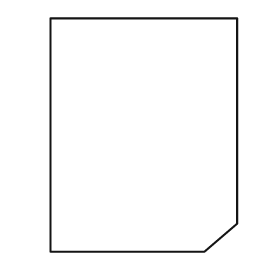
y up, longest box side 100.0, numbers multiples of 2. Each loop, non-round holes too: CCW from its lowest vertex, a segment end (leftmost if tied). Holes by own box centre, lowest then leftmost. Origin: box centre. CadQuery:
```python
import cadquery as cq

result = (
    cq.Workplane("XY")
    .moveTo(-40.0, -50.0)
    .lineTo(26.0, -50.0)
    .lineTo(40.0, -38.0)
    .lineTo(40.0, 50.0)
    .lineTo(-40.0, 50.0)
    .close()
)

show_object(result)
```